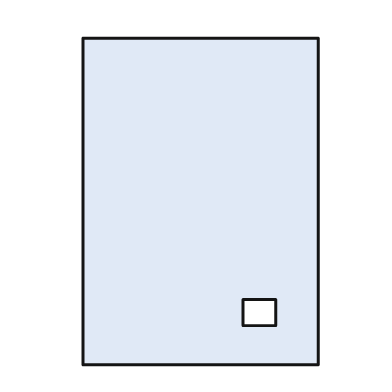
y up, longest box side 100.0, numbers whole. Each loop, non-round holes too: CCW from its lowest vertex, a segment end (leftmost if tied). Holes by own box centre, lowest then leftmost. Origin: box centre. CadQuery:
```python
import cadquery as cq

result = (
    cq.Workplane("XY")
    .moveTo(-36.0, -50.0)
    .lineTo(36.0, -50.0)
    .lineTo(36.0, 50.0)
    .lineTo(-36.0, 50.0)
    .close()
    .moveTo(13.0, -38.0)
    .lineTo(23.0, -38.0)
    .lineTo(23.0, -30.0)
    .lineTo(13.0, -30.0)
    .close()
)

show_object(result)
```